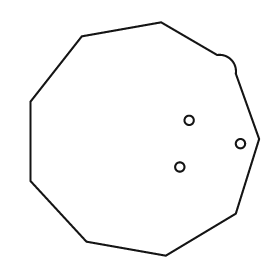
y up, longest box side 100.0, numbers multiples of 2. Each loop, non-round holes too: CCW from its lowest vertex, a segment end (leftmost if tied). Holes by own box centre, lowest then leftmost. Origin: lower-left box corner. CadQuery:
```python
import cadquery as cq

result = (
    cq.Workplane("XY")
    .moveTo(58.0, 0.0)
    .lineTo(88.0, 18.0)
    .lineTo(98.0, 50.0)
    .lineTo(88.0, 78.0)
    .threePointArc((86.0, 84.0), (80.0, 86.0))
    .lineTo(56.0, 100.0)
    .lineTo(22.0, 94.0)
    .lineTo(0.0, 66.0)
    .lineTo(0.0, 32.0)
    .lineTo(24.0, 6.0)
    .close()
    .moveTo(64.0, 38.0)
    .circle(2.0)
    .moveTo(90.0, 48.0)
    .circle(2.0)
    .moveTo(68.0, 58.0)
    .circle(2.0)
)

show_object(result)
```